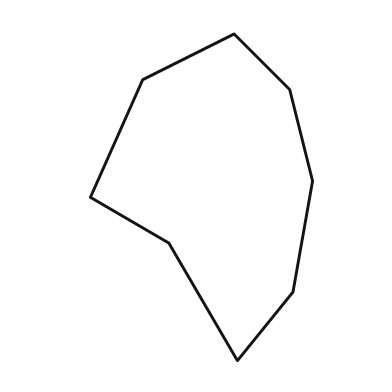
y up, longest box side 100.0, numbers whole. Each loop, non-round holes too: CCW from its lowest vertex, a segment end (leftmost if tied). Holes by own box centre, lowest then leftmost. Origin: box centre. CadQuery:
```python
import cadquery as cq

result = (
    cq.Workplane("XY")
    .moveTo(11.0, -50.0)
    .lineTo(28.0, -29.0)
    .lineTo(34.0, 5.0)
    .lineTo(27.0, 33.0)
    .lineTo(10.0, 50.0)
    .lineTo(-18.0, 36.0)
    .lineTo(-34.0, 0.0)
    .lineTo(-10.0, -14.0)
    .close()
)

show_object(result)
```